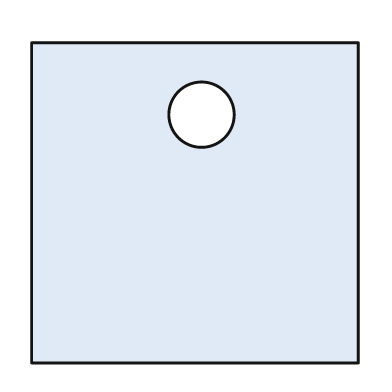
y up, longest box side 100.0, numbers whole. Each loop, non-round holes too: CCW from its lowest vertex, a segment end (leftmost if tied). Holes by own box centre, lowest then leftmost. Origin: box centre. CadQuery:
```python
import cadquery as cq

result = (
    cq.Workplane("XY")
    .moveTo(-50.0, -49.0)
    .lineTo(50.0, -49.0)
    .lineTo(50.0, 49.0)
    .lineTo(-50.0, 49.0)
    .close()
    .moveTo(2.0, 27.0)
    .circle(10.0)
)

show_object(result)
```